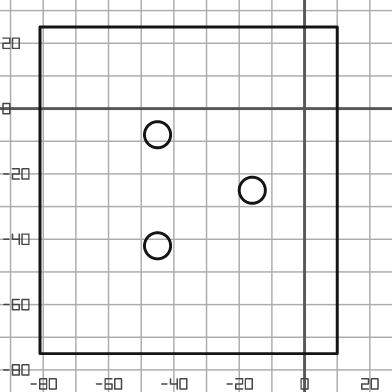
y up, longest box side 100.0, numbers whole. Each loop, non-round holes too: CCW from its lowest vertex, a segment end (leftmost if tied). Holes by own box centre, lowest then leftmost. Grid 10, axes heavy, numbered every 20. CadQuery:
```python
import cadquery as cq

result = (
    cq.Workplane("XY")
    .moveTo(-81.0, -75.0)
    .lineTo(10.0, -75.0)
    .lineTo(10.0, 25.0)
    .lineTo(-81.0, 25.0)
    .close()
    .moveTo(-45.0, -42.0)
    .circle(4.0)
    .moveTo(-16.0, -25.0)
    .circle(4.0)
    .moveTo(-45.0, -8.0)
    .circle(4.0)
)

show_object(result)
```